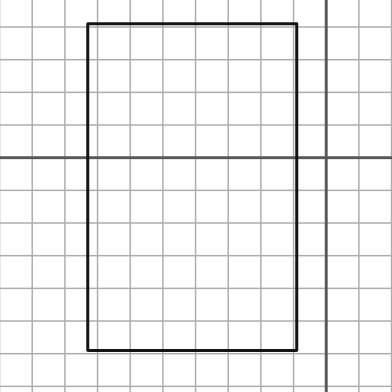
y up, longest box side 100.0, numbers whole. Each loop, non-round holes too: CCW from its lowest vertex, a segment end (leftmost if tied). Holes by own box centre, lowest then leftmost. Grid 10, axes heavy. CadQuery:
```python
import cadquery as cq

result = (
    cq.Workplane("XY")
    .moveTo(-73.0, -59.0)
    .lineTo(-9.0, -59.0)
    .lineTo(-9.0, 41.0)
    .lineTo(-73.0, 41.0)
    .close()
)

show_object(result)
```